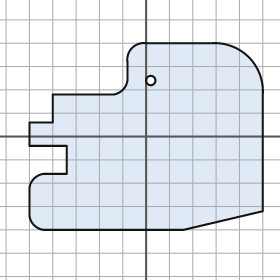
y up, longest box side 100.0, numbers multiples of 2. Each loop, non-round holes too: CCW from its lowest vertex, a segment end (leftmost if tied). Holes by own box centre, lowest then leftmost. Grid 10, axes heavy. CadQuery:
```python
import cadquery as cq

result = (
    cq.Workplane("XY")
    .moveTo(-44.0, -40.0)
    .lineTo(16.0, -40.0)
    .lineTo(50.0, -32.0)
    .lineTo(50.0, 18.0)
    .threePointArc((44.0, 34.0), (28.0, 40.0))
    .lineTo(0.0, 40.0)
    .threePointArc((-6.0, 38.0), (-8.0, 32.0))
    .lineTo(-8.0, 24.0)
    .threePointArc((-10.0, 20.0), (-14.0, 18.0))
    .lineTo(-40.0, 18.0)
    .lineTo(-40.0, 6.0)
    .lineTo(-50.0, 6.0)
    .lineTo(-50.0, -4.0)
    .lineTo(-34.0, -4.0)
    .lineTo(-34.0, -16.0)
    .lineTo(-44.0, -16.0)
    .threePointArc((-48.0, -18.0), (-50.0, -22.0))
    .lineTo(-50.0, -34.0)
    .threePointArc((-48.0, -38.0), (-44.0, -40.0))
    .close()
    .moveTo(2.0, 24.0)
    .circle(2.0)
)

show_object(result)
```